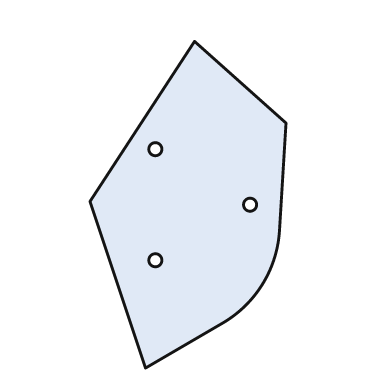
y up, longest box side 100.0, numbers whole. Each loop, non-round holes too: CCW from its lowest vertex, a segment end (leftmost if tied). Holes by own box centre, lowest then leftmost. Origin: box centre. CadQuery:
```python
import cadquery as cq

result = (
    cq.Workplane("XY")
    .moveTo(-13.0, -50.0)
    .lineTo(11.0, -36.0)
    .threePointArc((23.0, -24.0), (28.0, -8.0))
    .lineTo(30.0, 25.0)
    .lineTo(2.0, 50.0)
    .lineTo(-30.0, 1.0)
    .close()
    .moveTo(-10.0, -17.0)
    .circle(2.0)
    .moveTo(19.0, 0.0)
    .circle(2.0)
    .moveTo(-10.0, 17.0)
    .circle(2.0)
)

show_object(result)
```